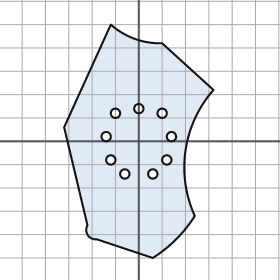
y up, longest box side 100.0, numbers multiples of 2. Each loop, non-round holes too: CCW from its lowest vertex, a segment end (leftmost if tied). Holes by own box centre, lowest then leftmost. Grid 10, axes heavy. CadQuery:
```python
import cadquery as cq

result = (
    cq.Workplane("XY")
    .moveTo(6.0, -50.0)
    .threePointArc((16.0, -42.0), (24.0, -32.0))
    .threePointArc((20.0, -4.0), (32.0, 22.0))
    .lineTo(10.0, 42.0)
    .threePointArc((-2.0, 44.0), (-12.0, 50.0))
    .lineTo(-32.0, 6.0)
    .lineTo(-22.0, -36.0)
    .threePointArc((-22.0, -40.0), (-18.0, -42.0))
    .close()
    .moveTo(-6.0, -14.0)
    .circle(2.0)
    .moveTo(6.0, -14.0)
    .circle(2.0)
    .moveTo(-12.0, -8.0)
    .circle(2.0)
    .moveTo(12.0, -8.0)
    .circle(2.0)
    .moveTo(-14.0, 2.0)
    .circle(2.0)
    .moveTo(14.0, 2.0)
    .circle(2.0)
    .moveTo(-10.0, 12.0)
    .circle(2.0)
    .moveTo(10.0, 12.0)
    .circle(2.0)
    .moveTo(0.0, 14.0)
    .circle(2.0)
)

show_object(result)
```